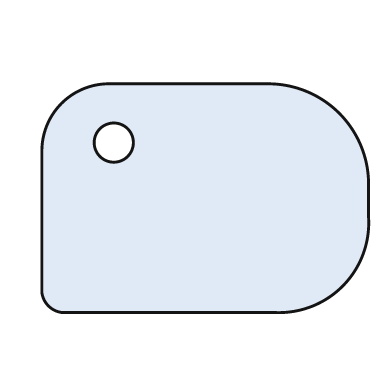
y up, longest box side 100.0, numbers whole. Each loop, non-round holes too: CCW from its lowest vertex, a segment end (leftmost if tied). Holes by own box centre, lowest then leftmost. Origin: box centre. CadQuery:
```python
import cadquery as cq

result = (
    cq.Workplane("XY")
    .moveTo(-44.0, -35.0)
    .lineTo(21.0, -35.0)
    .threePointArc((42.0, -27.0), (50.0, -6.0))
    .lineTo(50.0, 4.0)
    .threePointArc((41.0, 26.0), (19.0, 35.0))
    .lineTo(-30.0, 35.0)
    .threePointArc((-44.0, 29.0), (-50.0, 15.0))
    .lineTo(-50.0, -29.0)
    .threePointArc((-48.0, -33.0), (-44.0, -35.0))
    .close()
    .moveTo(-28.0, 17.0)
    .circle(6.0)
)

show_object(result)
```